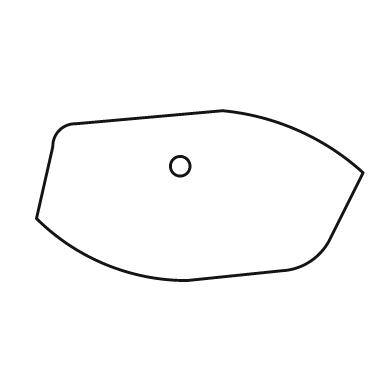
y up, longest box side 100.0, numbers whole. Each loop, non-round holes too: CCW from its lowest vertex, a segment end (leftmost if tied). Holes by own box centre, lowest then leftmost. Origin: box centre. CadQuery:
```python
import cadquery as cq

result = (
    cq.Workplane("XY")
    .moveTo(-4.0, -26.0)
    .lineTo(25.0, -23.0)
    .threePointArc((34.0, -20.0), (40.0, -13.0))
    .lineTo(50.0, 7.0)
    .threePointArc((30.0, 20.0), (7.0, 26.0))
    .lineTo(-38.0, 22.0)
    .threePointArc((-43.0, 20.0), (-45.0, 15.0))
    .lineTo(-50.0, -7.0)
    .threePointArc((-29.0, -21.0), (-4.0, -26.0))
    .close()
    .moveTo(-6.0, 9.0)
    .circle(3.0)
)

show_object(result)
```